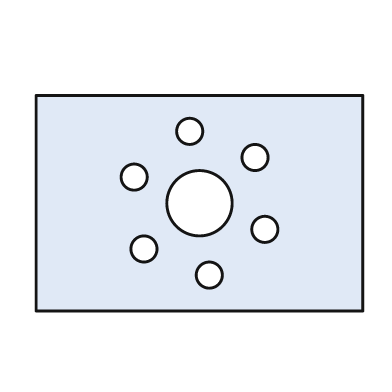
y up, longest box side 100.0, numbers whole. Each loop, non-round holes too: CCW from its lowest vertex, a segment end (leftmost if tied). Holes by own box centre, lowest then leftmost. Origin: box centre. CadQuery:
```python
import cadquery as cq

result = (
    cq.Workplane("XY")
    .moveTo(-50.0, -33.0)
    .lineTo(50.0, -33.0)
    .lineTo(50.0, 33.0)
    .lineTo(-50.0, 33.0)
    .close()
    .moveTo(3.0, -22.0)
    .circle(4.0)
    .moveTo(-17.0, -14.0)
    .circle(4.0)
    .moveTo(20.0, -8.0)
    .circle(4.0)
    .moveTo(0.0, 0.0)
    .circle(10.0)
    .moveTo(-20.0, 8.0)
    .circle(4.0)
    .moveTo(17.0, 14.0)
    .circle(4.0)
    .moveTo(-3.0, 22.0)
    .circle(4.0)
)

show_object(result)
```